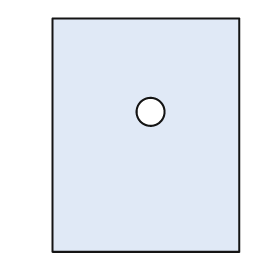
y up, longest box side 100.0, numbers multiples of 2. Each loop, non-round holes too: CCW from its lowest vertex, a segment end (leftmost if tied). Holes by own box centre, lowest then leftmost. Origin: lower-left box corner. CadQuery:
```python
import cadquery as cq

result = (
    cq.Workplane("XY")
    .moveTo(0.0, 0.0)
    .lineTo(80.0, 0.0)
    .lineTo(80.0, 100.0)
    .lineTo(0.0, 100.0)
    .close()
    .moveTo(42.0, 60.0)
    .circle(6.0)
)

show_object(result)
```